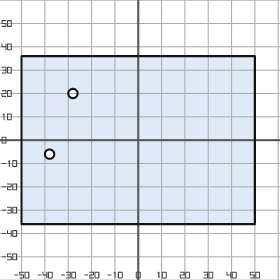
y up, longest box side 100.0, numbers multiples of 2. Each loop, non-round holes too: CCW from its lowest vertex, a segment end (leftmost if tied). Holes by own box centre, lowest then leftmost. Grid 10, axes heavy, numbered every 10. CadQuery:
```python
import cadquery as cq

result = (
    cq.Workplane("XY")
    .moveTo(-50.0, -36.0)
    .lineTo(50.0, -36.0)
    .lineTo(50.0, 36.0)
    .lineTo(-50.0, 36.0)
    .close()
    .moveTo(-38.0, -6.0)
    .circle(2.0)
    .moveTo(-28.0, 20.0)
    .circle(2.0)
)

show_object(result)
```